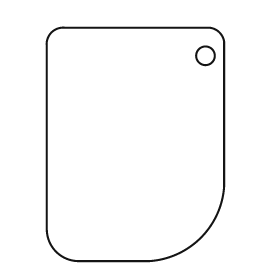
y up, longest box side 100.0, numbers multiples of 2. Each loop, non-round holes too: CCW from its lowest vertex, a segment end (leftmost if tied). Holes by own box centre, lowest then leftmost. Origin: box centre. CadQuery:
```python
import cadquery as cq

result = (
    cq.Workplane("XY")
    .moveTo(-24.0, -50.0)
    .lineTo(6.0, -50.0)
    .threePointArc((28.0, -40.0), (38.0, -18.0))
    .lineTo(38.0, 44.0)
    .threePointArc((36.0, 48.0), (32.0, 50.0))
    .lineTo(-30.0, 50.0)
    .threePointArc((-36.0, 48.0), (-38.0, 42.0))
    .lineTo(-38.0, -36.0)
    .threePointArc((-34.0, -46.0), (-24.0, -50.0))
    .close()
    .moveTo(30.0, 38.0)
    .circle(4.0)
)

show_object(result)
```